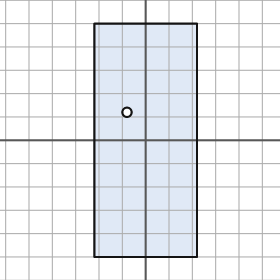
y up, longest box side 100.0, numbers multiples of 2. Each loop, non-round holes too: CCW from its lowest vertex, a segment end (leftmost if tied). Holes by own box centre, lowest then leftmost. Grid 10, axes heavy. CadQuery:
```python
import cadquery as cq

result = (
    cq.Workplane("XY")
    .moveTo(-22.0, -50.0)
    .lineTo(22.0, -50.0)
    .lineTo(22.0, 50.0)
    .lineTo(-22.0, 50.0)
    .close()
    .moveTo(-8.0, 12.0)
    .circle(2.0)
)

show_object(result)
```